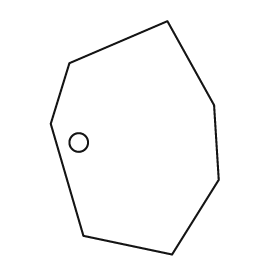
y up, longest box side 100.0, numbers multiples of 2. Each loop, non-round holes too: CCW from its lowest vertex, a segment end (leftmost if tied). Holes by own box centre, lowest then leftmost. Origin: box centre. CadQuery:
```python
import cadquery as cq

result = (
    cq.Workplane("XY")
    .moveTo(16.0, -50.0)
    .lineTo(36.0, -18.0)
    .lineTo(34.0, 14.0)
    .lineTo(14.0, 50.0)
    .lineTo(-28.0, 32.0)
    .lineTo(-36.0, 6.0)
    .lineTo(-22.0, -42.0)
    .close()
    .moveTo(-24.0, -2.0)
    .circle(4.0)
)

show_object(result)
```